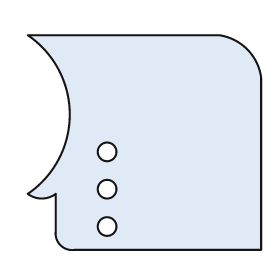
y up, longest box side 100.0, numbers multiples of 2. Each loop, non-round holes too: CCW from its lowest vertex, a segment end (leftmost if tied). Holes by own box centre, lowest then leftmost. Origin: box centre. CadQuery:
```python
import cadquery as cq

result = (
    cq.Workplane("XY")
    .moveTo(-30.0, -46.0)
    .lineTo(50.0, -46.0)
    .lineTo(50.0, 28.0)
    .threePointArc((44.0, 40.0), (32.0, 46.0))
    .lineTo(-50.0, 46.0)
    .threePointArc((-32.0, 12.0), (-50.0, -22.0))
    .threePointArc((-44.0, -24.0), (-38.0, -22.0))
    .lineTo(-38.0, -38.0)
    .threePointArc((-36.0, -44.0), (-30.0, -46.0))
    .close()
    .moveTo(-16.0, -36.0)
    .circle(4.0)
    .moveTo(-16.0, -20.0)
    .circle(4.0)
    .moveTo(-16.0, -4.0)
    .circle(4.0)
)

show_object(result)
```